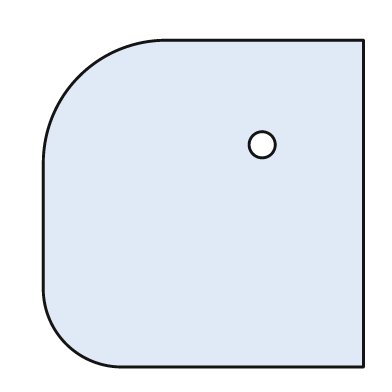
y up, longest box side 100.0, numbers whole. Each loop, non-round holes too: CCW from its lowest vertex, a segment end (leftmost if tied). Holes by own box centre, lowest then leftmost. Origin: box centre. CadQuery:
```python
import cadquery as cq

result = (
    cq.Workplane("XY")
    .moveTo(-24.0, -50.0)
    .lineTo(49.0, -50.0)
    .lineTo(49.0, 50.0)
    .lineTo(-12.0, 50.0)
    .threePointArc((-38.0, 39.0), (-49.0, 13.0))
    .lineTo(-49.0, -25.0)
    .threePointArc((-42.0, -43.0), (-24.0, -50.0))
    .close()
    .moveTo(18.0, 18.0)
    .circle(4.0)
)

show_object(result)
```